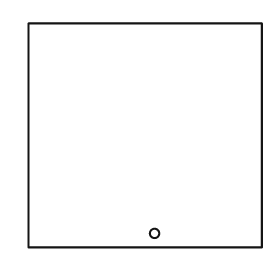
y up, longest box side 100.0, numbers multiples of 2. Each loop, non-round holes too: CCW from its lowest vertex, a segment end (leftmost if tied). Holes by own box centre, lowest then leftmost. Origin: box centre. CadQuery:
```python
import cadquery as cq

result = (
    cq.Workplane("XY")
    .moveTo(-50.0, -48.0)
    .lineTo(50.0, -48.0)
    .lineTo(50.0, 48.0)
    .lineTo(-50.0, 48.0)
    .close()
    .moveTo(4.0, -42.0)
    .circle(2.0)
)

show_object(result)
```